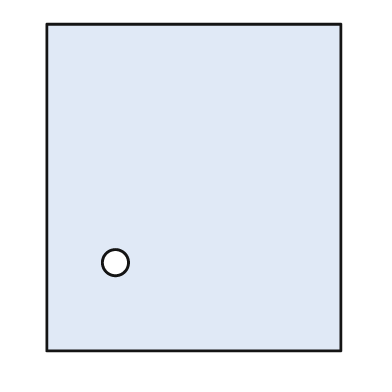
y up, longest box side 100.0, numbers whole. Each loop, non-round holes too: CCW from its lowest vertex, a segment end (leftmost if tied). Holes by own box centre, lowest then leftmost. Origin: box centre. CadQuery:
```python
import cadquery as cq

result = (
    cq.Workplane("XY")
    .moveTo(-45.0, -50.0)
    .lineTo(45.0, -50.0)
    .lineTo(45.0, 50.0)
    .lineTo(-45.0, 50.0)
    .close()
    .moveTo(-24.0, -23.0)
    .circle(4.0)
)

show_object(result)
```